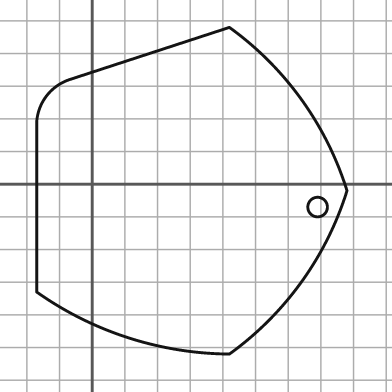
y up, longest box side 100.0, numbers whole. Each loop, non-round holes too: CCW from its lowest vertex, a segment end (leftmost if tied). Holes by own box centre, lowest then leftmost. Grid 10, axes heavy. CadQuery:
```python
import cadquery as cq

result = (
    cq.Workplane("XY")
    .moveTo(42.0, -52.0)
    .threePointArc((64.0, -30.0), (78.0, -2.0))
    .threePointArc((64.0, 26.0), (42.0, 48.0))
    .lineTo(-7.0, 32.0)
    .threePointArc((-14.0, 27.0), (-17.0, 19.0))
    .lineTo(-17.0, -33.0)
    .threePointArc((11.0, -47.0), (42.0, -52.0))
    .close()
    .moveTo(69.0, -7.0)
    .circle(3.0)
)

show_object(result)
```